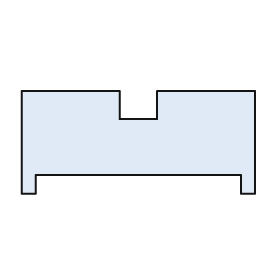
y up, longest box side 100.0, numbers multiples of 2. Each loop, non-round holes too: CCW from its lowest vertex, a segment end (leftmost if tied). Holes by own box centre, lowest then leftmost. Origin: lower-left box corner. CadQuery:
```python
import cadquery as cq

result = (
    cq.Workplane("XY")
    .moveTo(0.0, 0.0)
    .lineTo(6.0, 0.0)
    .lineTo(6.0, 8.0)
    .lineTo(94.0, 8.0)
    .lineTo(94.0, 0.0)
    .lineTo(100.0, 0.0)
    .lineTo(100.0, 44.0)
    .lineTo(58.0, 44.0)
    .lineTo(58.0, 32.0)
    .lineTo(42.0, 32.0)
    .lineTo(42.0, 44.0)
    .lineTo(0.0, 44.0)
    .close()
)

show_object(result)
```